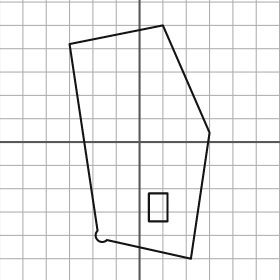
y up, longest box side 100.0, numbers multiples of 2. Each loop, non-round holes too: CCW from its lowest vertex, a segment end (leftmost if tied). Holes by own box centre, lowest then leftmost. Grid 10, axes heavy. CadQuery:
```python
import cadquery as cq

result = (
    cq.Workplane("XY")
    .moveTo(22.0, -50.0)
    .lineTo(30.0, 4.0)
    .lineTo(10.0, 50.0)
    .lineTo(-30.0, 42.0)
    .lineTo(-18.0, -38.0)
    .threePointArc((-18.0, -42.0), (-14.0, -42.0))
    .close()
    .moveTo(4.0, -34.0)
    .lineTo(12.0, -34.0)
    .lineTo(12.0, -22.0)
    .lineTo(4.0, -22.0)
    .close()
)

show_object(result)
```